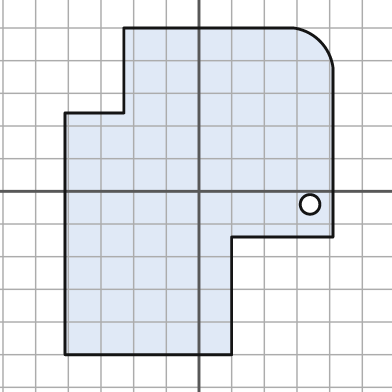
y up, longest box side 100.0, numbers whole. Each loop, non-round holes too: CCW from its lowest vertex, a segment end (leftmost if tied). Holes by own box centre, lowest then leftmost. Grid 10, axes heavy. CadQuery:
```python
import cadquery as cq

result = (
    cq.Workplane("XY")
    .moveTo(-41.0, -50.0)
    .lineTo(10.0, -50.0)
    .lineTo(10.0, -14.0)
    .lineTo(41.0, -14.0)
    .lineTo(41.0, 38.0)
    .threePointArc((37.0, 46.0), (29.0, 50.0))
    .lineTo(-23.0, 50.0)
    .lineTo(-23.0, 24.0)
    .lineTo(-41.0, 24.0)
    .close()
    .moveTo(34.0, -4.0)
    .circle(3.0)
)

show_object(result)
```